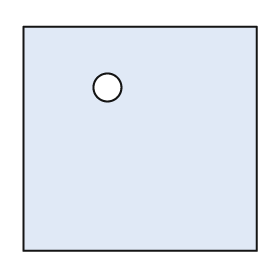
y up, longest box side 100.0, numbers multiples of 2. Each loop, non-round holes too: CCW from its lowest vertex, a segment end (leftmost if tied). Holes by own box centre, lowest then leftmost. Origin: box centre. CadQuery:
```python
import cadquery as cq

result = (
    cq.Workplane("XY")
    .moveTo(-50.0, -48.0)
    .lineTo(50.0, -48.0)
    .lineTo(50.0, 48.0)
    .lineTo(-50.0, 48.0)
    .close()
    .moveTo(-14.0, 22.0)
    .circle(6.0)
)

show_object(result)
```